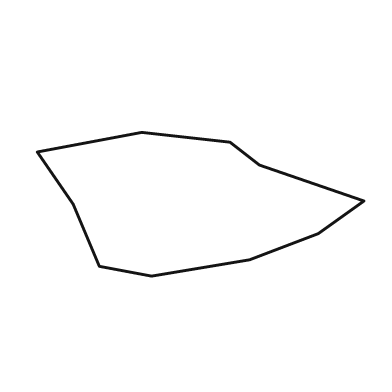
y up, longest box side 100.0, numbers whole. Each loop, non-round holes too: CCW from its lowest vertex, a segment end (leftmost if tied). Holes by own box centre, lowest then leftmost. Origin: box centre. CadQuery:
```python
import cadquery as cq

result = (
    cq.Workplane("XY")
    .moveTo(-15.0, -22.0)
    .lineTo(15.0, -17.0)
    .lineTo(36.0, -9.0)
    .lineTo(50.0, 1.0)
    .lineTo(18.0, 12.0)
    .lineTo(9.0, 19.0)
    .lineTo(-18.0, 22.0)
    .lineTo(-50.0, 16.0)
    .lineTo(-39.0, 0.0)
    .lineTo(-31.0, -19.0)
    .close()
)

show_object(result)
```